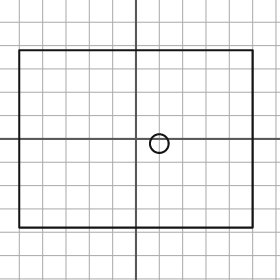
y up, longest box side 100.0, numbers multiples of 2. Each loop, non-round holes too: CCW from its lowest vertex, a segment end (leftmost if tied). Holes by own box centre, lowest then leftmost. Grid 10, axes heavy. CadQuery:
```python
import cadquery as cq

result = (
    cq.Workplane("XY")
    .moveTo(-50.0, -38.0)
    .lineTo(50.0, -38.0)
    .lineTo(50.0, 38.0)
    .lineTo(-50.0, 38.0)
    .close()
    .moveTo(10.0, -2.0)
    .circle(4.0)
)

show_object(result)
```